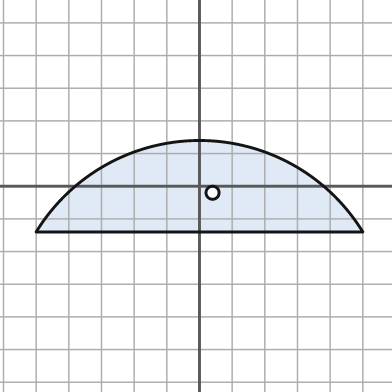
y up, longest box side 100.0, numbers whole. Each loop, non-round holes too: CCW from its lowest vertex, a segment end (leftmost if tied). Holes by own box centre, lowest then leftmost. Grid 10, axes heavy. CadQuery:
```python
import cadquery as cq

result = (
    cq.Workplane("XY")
    .moveTo(-50.0, -14.0)
    .lineTo(50.0, -14.0)
    .threePointArc((0.0, 14.0), (-50.0, -14.0))
    .close()
    .moveTo(4.0, -2.0)
    .circle(2.0)
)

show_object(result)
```